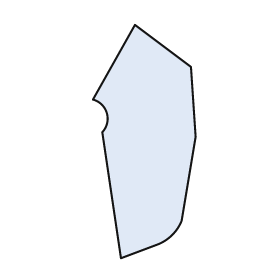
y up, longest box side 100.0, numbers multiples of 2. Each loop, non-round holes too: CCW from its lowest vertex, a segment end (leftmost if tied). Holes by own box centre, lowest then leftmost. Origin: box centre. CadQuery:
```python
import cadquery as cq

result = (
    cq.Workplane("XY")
    .moveTo(-10.0, -50.0)
    .lineTo(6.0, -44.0)
    .threePointArc((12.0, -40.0), (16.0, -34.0))
    .lineTo(22.0, 2.0)
    .lineTo(20.0, 32.0)
    .lineTo(-4.0, 50.0)
    .lineTo(-22.0, 18.0)
    .threePointArc((-16.0, 12.0), (-18.0, 4.0))
    .close()
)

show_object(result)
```